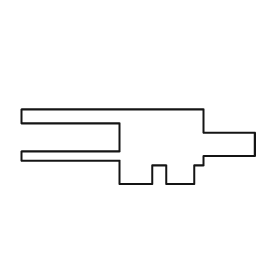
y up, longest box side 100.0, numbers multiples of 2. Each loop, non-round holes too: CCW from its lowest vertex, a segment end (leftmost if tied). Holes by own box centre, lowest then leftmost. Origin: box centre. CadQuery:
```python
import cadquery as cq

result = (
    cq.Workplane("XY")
    .moveTo(-8.0, -16.0)
    .lineTo(6.0, -16.0)
    .lineTo(6.0, -8.0)
    .lineTo(12.0, -8.0)
    .lineTo(12.0, -16.0)
    .lineTo(24.0, -16.0)
    .lineTo(24.0, -8.0)
    .lineTo(28.0, -8.0)
    .lineTo(28.0, -4.0)
    .lineTo(50.0, -4.0)
    .lineTo(50.0, 6.0)
    .lineTo(28.0, 6.0)
    .lineTo(28.0, 16.0)
    .lineTo(-50.0, 16.0)
    .lineTo(-50.0, 10.0)
    .lineTo(-8.0, 10.0)
    .lineTo(-8.0, -2.0)
    .lineTo(-50.0, -2.0)
    .lineTo(-50.0, -6.0)
    .lineTo(-8.0, -6.0)
    .close()
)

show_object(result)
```